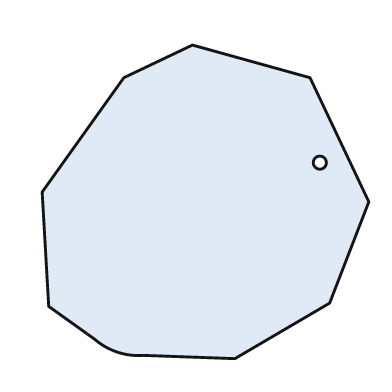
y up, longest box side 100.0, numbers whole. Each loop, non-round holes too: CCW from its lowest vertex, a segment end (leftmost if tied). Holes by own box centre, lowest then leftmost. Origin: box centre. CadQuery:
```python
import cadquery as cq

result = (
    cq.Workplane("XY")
    .moveTo(9.0, -48.0)
    .lineTo(38.0, -31.0)
    .lineTo(50.0, 0.0)
    .lineTo(32.0, 38.0)
    .lineTo(-4.0, 48.0)
    .lineTo(-25.0, 38.0)
    .lineTo(-50.0, 3.0)
    .lineTo(-48.0, -32.0)
    .lineTo(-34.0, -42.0)
    .threePointArc((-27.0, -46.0), (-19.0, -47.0))
    .close()
    .moveTo(35.0, 12.0)
    .circle(2.0)
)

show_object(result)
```